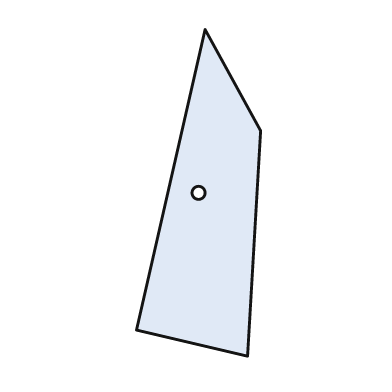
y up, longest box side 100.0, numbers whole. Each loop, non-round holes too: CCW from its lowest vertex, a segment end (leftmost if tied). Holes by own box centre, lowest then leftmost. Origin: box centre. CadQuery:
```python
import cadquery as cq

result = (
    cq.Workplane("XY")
    .moveTo(15.0, -50.0)
    .lineTo(19.0, 19.0)
    .lineTo(2.0, 50.0)
    .lineTo(-19.0, -42.0)
    .close()
    .moveTo(0.0, 0.0)
    .circle(2.0)
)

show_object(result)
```